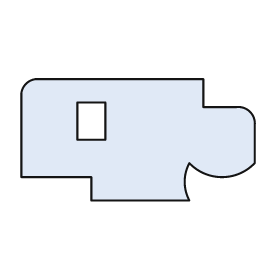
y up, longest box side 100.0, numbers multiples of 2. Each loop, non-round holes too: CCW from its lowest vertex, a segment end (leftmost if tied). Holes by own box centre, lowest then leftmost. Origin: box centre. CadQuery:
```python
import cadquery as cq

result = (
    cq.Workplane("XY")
    .moveTo(-20.0, -26.0)
    .lineTo(22.0, -26.0)
    .threePointArc((20.0, -18.0), (22.0, -10.0))
    .threePointArc((36.0, -16.0), (50.0, -10.0))
    .lineTo(50.0, 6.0)
    .threePointArc((48.0, 12.0), (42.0, 14.0))
    .lineTo(28.0, 14.0)
    .lineTo(28.0, 26.0)
    .lineTo(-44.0, 26.0)
    .threePointArc((-48.0, 24.0), (-50.0, 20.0))
    .lineTo(-50.0, -16.0)
    .lineTo(-20.0, -16.0)
    .close()
    .moveTo(-26.0, 0.0)
    .lineTo(-14.0, 0.0)
    .lineTo(-14.0, 16.0)
    .lineTo(-26.0, 16.0)
    .close()
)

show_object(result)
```